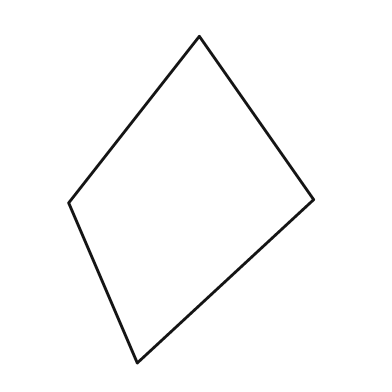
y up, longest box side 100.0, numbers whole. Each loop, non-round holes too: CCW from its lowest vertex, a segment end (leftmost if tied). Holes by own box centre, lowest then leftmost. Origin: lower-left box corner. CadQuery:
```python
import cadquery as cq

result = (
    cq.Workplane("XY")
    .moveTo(21.0, 0.0)
    .lineTo(75.0, 50.0)
    .lineTo(40.0, 100.0)
    .lineTo(0.0, 49.0)
    .close()
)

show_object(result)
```